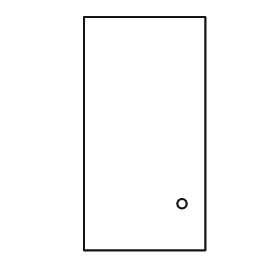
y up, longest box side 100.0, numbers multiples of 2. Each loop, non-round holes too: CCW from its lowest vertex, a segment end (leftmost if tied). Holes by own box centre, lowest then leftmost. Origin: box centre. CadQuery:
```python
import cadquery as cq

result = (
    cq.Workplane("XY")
    .moveTo(-26.0, -50.0)
    .lineTo(26.0, -50.0)
    .lineTo(26.0, 50.0)
    .lineTo(-26.0, 50.0)
    .close()
    .moveTo(16.0, -30.0)
    .circle(2.0)
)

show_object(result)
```